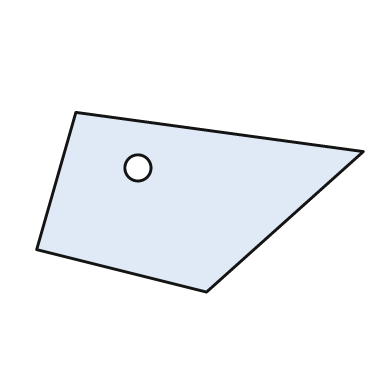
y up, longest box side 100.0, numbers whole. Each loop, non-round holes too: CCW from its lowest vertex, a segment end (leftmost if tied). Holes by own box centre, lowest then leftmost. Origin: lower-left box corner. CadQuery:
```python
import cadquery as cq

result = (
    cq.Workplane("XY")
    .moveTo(52.0, 0.0)
    .lineTo(100.0, 43.0)
    .lineTo(12.0, 55.0)
    .lineTo(0.0, 13.0)
    .close()
    .moveTo(31.0, 38.0)
    .circle(4.0)
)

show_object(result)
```